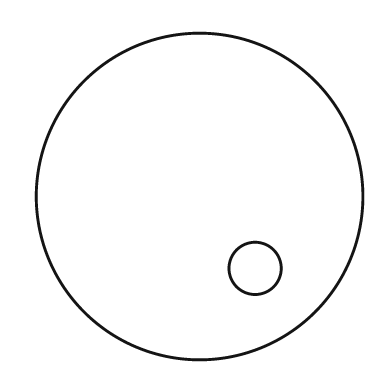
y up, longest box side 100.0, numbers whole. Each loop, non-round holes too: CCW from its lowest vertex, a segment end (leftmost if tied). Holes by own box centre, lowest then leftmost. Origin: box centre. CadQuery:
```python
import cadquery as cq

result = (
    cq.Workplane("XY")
    .moveTo(0.0, 0.0)
    .circle(50.0)
    .moveTo(17.0, -22.0)
    .circle(8.0)
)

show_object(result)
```